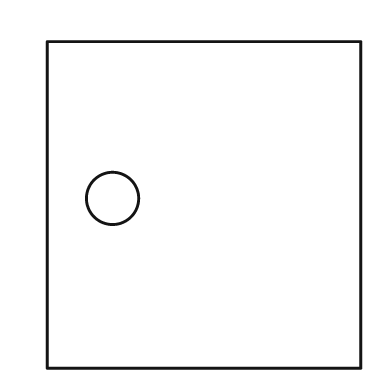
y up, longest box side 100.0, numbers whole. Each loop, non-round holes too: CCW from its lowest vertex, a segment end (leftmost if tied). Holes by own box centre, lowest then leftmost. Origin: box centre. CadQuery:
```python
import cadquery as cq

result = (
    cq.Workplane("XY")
    .moveTo(-48.0, -50.0)
    .lineTo(48.0, -50.0)
    .lineTo(48.0, 50.0)
    .lineTo(-48.0, 50.0)
    .close()
    .moveTo(-28.0, 2.0)
    .circle(8.0)
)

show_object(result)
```